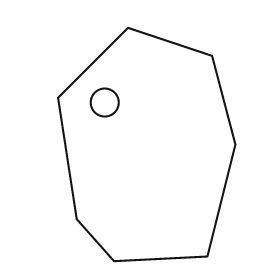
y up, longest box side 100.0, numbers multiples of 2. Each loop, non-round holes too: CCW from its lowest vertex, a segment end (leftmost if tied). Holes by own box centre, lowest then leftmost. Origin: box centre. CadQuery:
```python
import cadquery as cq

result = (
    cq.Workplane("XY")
    .moveTo(-14.0, -50.0)
    .lineTo(26.0, -48.0)
    .lineTo(38.0, 0.0)
    .lineTo(28.0, 38.0)
    .lineTo(-8.0, 50.0)
    .lineTo(-38.0, 20.0)
    .lineTo(-30.0, -32.0)
    .close()
    .moveTo(-18.0, 18.0)
    .circle(6.0)
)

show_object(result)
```